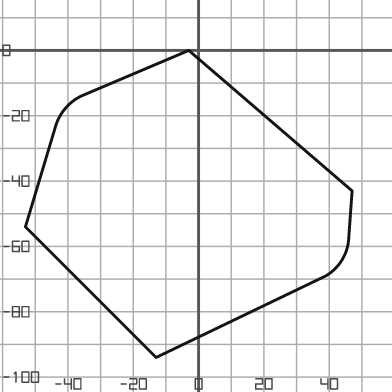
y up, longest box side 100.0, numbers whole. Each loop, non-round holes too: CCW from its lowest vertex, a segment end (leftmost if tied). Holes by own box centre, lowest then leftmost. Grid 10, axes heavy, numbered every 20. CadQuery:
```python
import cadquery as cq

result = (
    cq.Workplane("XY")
    .moveTo(-13.0, -94.0)
    .lineTo(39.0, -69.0)
    .threePointArc((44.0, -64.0), (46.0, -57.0))
    .lineTo(47.0, -43.0)
    .lineTo(-3.0, 0.0)
    .lineTo(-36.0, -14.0)
    .threePointArc((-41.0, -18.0), (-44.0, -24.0))
    .lineTo(-53.0, -54.0)
    .close()
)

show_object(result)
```